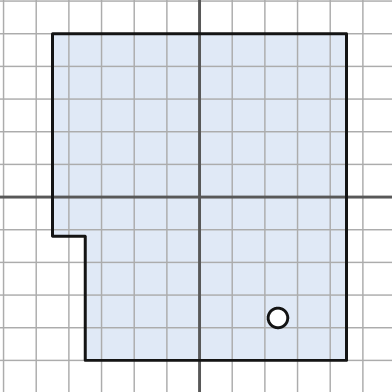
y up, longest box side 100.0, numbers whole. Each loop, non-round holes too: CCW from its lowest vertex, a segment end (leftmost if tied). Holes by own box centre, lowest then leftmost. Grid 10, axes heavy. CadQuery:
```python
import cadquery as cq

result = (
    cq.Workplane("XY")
    .moveTo(-35.0, -50.0)
    .lineTo(45.0, -50.0)
    .lineTo(45.0, 50.0)
    .lineTo(-45.0, 50.0)
    .lineTo(-45.0, -12.0)
    .lineTo(-35.0, -12.0)
    .close()
    .moveTo(24.0, -37.0)
    .circle(3.0)
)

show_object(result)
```